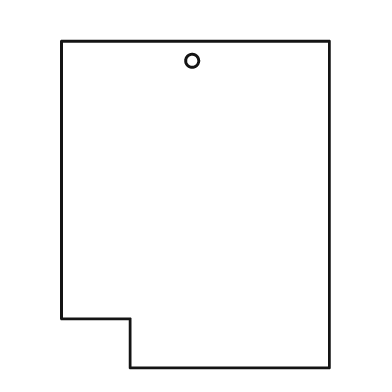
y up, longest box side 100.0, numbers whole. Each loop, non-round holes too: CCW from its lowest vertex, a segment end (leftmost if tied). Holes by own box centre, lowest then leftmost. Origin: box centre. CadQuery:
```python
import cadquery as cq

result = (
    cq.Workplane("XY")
    .moveTo(-20.0, -50.0)
    .lineTo(41.0, -50.0)
    .lineTo(41.0, 50.0)
    .lineTo(-41.0, 50.0)
    .lineTo(-41.0, -35.0)
    .lineTo(-20.0, -35.0)
    .close()
    .moveTo(-1.0, 44.0)
    .circle(2.0)
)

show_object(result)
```